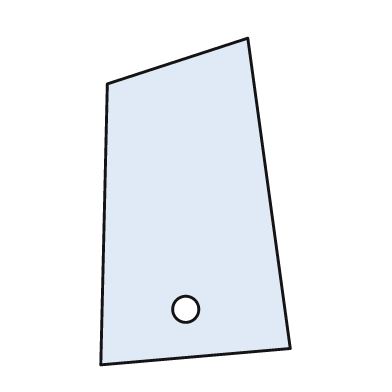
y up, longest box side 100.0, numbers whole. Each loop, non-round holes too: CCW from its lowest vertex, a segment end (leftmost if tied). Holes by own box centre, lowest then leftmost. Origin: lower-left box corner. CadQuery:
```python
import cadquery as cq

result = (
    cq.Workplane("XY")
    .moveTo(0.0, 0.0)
    .lineTo(58.0, 5.0)
    .lineTo(45.0, 100.0)
    .lineTo(2.0, 86.0)
    .close()
    .moveTo(26.0, 17.0)
    .circle(4.0)
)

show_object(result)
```